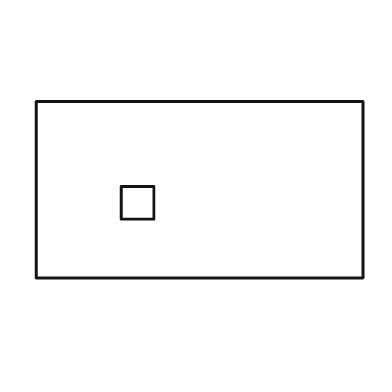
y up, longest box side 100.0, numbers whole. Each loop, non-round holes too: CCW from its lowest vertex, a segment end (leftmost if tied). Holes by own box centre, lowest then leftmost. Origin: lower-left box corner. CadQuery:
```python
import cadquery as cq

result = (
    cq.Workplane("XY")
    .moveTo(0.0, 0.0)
    .lineTo(100.0, 0.0)
    .lineTo(100.0, 54.0)
    .lineTo(0.0, 54.0)
    .close()
    .moveTo(26.0, 18.0)
    .lineTo(36.0, 18.0)
    .lineTo(36.0, 28.0)
    .lineTo(26.0, 28.0)
    .close()
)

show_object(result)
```